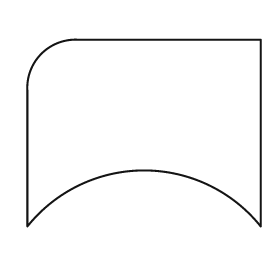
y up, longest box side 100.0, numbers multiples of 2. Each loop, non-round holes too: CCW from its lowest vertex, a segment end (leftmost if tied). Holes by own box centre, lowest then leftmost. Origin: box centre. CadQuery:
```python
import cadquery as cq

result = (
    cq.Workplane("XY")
    .moveTo(-50.0, -40.0)
    .threePointArc((0.0, -16.0), (50.0, -40.0))
    .lineTo(50.0, 40.0)
    .lineTo(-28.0, 40.0)
    .threePointArc((-44.0, 34.0), (-50.0, 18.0))
    .close()
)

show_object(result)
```